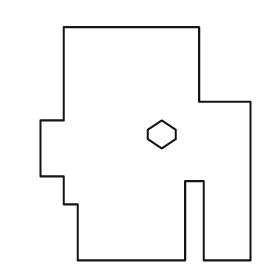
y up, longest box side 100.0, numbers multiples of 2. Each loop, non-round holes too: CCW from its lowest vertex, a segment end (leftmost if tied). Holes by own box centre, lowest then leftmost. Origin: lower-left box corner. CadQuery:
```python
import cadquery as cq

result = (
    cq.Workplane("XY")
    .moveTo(16.0, 0.0)
    .lineTo(62.0, 0.0)
    .lineTo(62.0, 34.0)
    .lineTo(70.0, 34.0)
    .lineTo(70.0, 0.0)
    .lineTo(90.0, 0.0)
    .lineTo(90.0, 68.0)
    .lineTo(68.0, 68.0)
    .lineTo(68.0, 100.0)
    .lineTo(10.0, 100.0)
    .lineTo(10.0, 60.0)
    .lineTo(0.0, 60.0)
    .lineTo(0.0, 36.0)
    .lineTo(10.0, 36.0)
    .lineTo(10.0, 24.0)
    .lineTo(16.0, 24.0)
    .close()
    .moveTo(52.0, 48.0)
    .lineTo(58.0, 52.0)
    .lineTo(58.0, 56.0)
    .lineTo(52.0, 60.0)
    .lineTo(46.0, 56.0)
    .lineTo(46.0, 52.0)
    .close()
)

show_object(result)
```